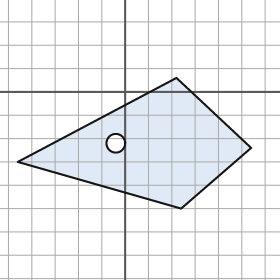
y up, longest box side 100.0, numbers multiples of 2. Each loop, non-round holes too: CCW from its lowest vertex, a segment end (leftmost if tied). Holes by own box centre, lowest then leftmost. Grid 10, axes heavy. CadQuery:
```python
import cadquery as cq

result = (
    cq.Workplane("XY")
    .moveTo(24.0, -50.0)
    .lineTo(54.0, -24.0)
    .lineTo(22.0, 6.0)
    .lineTo(-46.0, -30.0)
    .close()
    .moveTo(-4.0, -22.0)
    .circle(4.0)
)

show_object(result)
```